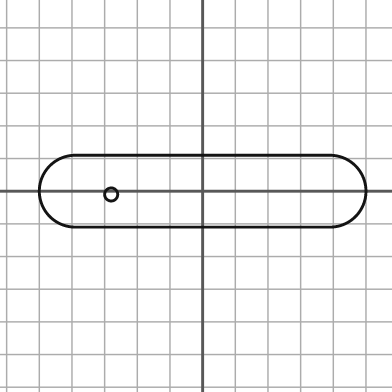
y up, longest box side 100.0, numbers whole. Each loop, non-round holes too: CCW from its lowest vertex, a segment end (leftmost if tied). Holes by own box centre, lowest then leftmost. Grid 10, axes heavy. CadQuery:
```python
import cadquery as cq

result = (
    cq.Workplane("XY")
    .moveTo(-39.0, -11.0)
    .lineTo(39.0, -11.0)
    .threePointArc((50.0, 0.0), (39.0, 11.0))
    .lineTo(-39.0, 11.0)
    .threePointArc((-50.0, 0.0), (-39.0, -11.0))
    .close()
    .moveTo(-28.0, -1.0)
    .circle(2.0)
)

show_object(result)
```